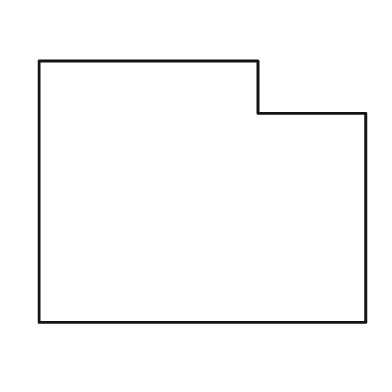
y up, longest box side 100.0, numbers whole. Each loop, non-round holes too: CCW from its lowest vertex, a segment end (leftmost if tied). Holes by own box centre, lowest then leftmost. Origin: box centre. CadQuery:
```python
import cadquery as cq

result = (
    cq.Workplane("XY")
    .moveTo(-50.0, -40.0)
    .lineTo(50.0, -40.0)
    .lineTo(50.0, 24.0)
    .lineTo(17.0, 24.0)
    .lineTo(17.0, 40.0)
    .lineTo(-50.0, 40.0)
    .close()
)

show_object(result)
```